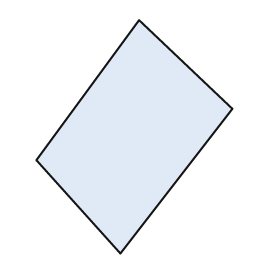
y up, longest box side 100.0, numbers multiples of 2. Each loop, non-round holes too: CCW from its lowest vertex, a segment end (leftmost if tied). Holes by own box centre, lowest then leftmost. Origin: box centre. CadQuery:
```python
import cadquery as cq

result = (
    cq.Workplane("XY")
    .moveTo(-6.0, -50.0)
    .lineTo(42.0, 12.0)
    .lineTo(2.0, 50.0)
    .lineTo(-42.0, -10.0)
    .close()
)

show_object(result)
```